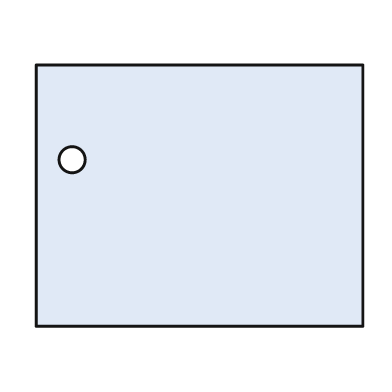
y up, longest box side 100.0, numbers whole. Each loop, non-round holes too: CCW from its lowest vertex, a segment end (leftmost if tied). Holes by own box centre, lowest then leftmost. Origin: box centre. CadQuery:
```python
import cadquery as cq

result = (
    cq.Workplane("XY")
    .moveTo(-50.0, -40.0)
    .lineTo(50.0, -40.0)
    .lineTo(50.0, 40.0)
    .lineTo(-50.0, 40.0)
    .close()
    .moveTo(-39.0, 11.0)
    .circle(4.0)
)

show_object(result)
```